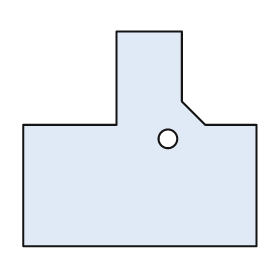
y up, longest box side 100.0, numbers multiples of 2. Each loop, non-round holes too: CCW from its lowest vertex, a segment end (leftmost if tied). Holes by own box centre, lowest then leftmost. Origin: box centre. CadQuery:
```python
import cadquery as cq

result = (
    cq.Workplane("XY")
    .moveTo(-50.0, -46.0)
    .lineTo(50.0, -46.0)
    .lineTo(50.0, 6.0)
    .lineTo(28.0, 6.0)
    .lineTo(18.0, 16.0)
    .lineTo(18.0, 46.0)
    .lineTo(-10.0, 46.0)
    .lineTo(-10.0, 6.0)
    .lineTo(-50.0, 6.0)
    .close()
    .moveTo(12.0, 0.0)
    .circle(4.0)
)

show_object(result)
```